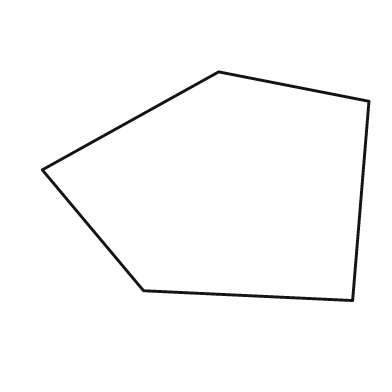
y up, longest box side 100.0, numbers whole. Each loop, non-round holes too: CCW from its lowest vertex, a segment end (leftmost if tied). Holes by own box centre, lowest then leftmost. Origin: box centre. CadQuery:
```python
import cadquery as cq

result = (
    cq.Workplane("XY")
    .moveTo(45.0, -35.0)
    .lineTo(50.0, 26.0)
    .lineTo(4.0, 35.0)
    .lineTo(-50.0, 5.0)
    .lineTo(-19.0, -32.0)
    .close()
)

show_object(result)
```